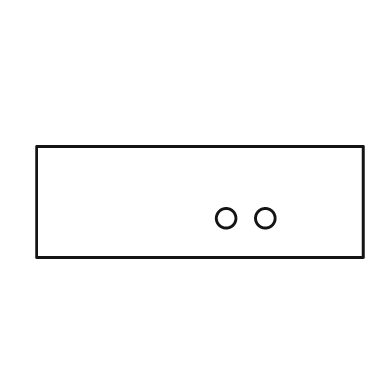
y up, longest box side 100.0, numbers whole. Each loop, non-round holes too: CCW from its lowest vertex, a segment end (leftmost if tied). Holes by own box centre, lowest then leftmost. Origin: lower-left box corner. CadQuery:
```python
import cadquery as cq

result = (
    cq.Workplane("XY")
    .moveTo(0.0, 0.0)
    .lineTo(100.0, 0.0)
    .lineTo(100.0, 34.0)
    .lineTo(0.0, 34.0)
    .close()
    .moveTo(58.0, 12.0)
    .circle(3.0)
    .moveTo(70.0, 12.0)
    .circle(3.0)
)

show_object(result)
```